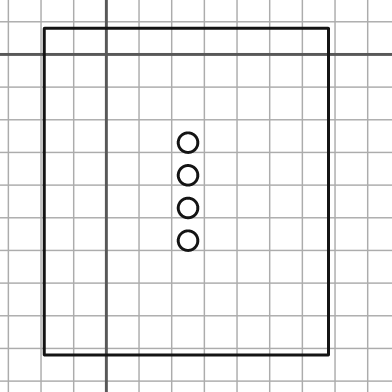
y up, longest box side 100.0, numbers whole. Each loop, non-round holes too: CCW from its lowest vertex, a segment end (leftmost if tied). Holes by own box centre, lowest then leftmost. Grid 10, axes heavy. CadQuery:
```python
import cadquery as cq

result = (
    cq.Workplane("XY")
    .moveTo(-19.0, -92.0)
    .lineTo(68.0, -92.0)
    .lineTo(68.0, 8.0)
    .lineTo(-19.0, 8.0)
    .close()
    .moveTo(25.0, -57.0)
    .circle(3.0)
    .moveTo(25.0, -47.0)
    .circle(3.0)
    .moveTo(25.0, -37.0)
    .circle(3.0)
    .moveTo(25.0, -27.0)
    .circle(3.0)
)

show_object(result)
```